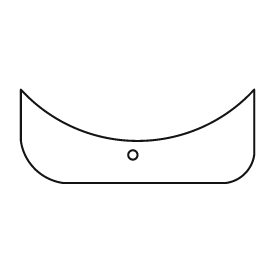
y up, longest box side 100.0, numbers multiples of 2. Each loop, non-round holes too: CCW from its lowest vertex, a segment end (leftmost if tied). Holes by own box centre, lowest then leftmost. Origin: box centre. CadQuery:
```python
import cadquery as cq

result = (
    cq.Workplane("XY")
    .moveTo(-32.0, -20.0)
    .lineTo(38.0, -20.0)
    .threePointArc((46.0, -16.0), (50.0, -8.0))
    .lineTo(50.0, 20.0)
    .threePointArc((0.0, -2.0), (-50.0, 20.0))
    .lineTo(-50.0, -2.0)
    .threePointArc((-44.0, -14.0), (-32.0, -20.0))
    .close()
    .moveTo(-2.0, -8.0)
    .circle(2.0)
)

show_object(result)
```